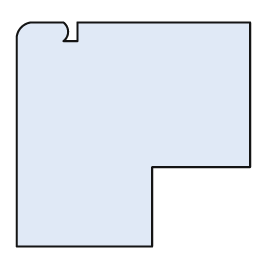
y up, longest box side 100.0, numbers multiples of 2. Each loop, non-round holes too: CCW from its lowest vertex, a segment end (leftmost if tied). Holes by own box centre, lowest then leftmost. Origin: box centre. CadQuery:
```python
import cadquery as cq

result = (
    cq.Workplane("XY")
    .moveTo(-50.0, -48.0)
    .lineTo(8.0, -48.0)
    .lineTo(8.0, -14.0)
    .lineTo(50.0, -14.0)
    .lineTo(50.0, 48.0)
    .lineTo(-24.0, 48.0)
    .lineTo(-24.0, 40.0)
    .lineTo(-30.0, 40.0)
    .threePointArc((-28.0, 44.0), (-30.0, 48.0))
    .lineTo(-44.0, 48.0)
    .threePointArc((-48.0, 46.0), (-50.0, 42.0))
    .close()
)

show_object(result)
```